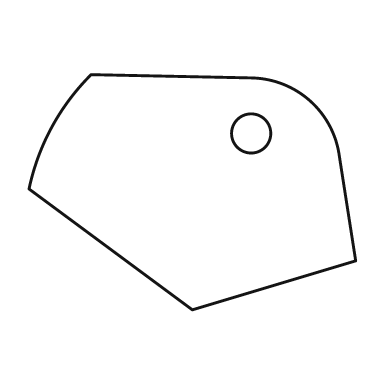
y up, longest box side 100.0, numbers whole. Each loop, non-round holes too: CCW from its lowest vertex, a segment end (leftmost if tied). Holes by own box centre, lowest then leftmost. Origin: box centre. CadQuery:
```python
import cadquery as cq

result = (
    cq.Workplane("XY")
    .moveTo(0.0, -36.0)
    .lineTo(50.0, -21.0)
    .lineTo(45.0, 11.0)
    .threePointArc((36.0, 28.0), (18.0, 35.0))
    .lineTo(-31.0, 36.0)
    .threePointArc((-43.0, 20.0), (-50.0, 1.0))
    .close()
    .moveTo(18.0, 18.0)
    .circle(6.0)
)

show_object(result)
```